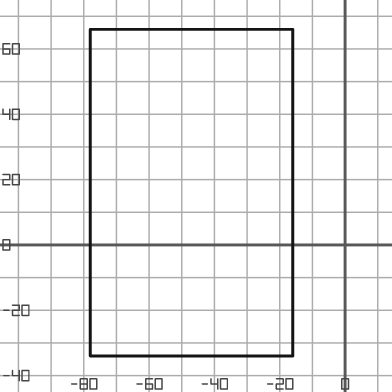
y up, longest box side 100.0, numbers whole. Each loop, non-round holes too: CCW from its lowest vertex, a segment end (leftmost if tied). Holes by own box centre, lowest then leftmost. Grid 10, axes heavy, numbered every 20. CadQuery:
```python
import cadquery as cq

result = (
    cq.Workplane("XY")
    .moveTo(-78.0, -34.0)
    .lineTo(-16.0, -34.0)
    .lineTo(-16.0, 66.0)
    .lineTo(-78.0, 66.0)
    .close()
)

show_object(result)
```